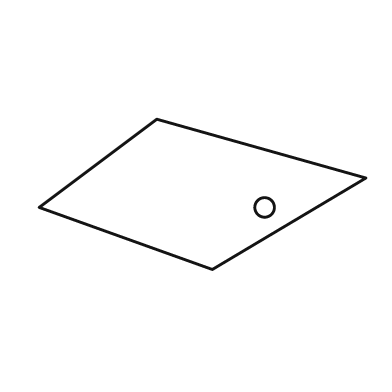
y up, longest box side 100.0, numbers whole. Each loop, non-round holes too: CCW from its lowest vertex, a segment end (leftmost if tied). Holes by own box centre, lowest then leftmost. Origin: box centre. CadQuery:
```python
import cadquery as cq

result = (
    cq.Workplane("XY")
    .moveTo(3.0, -23.0)
    .lineTo(50.0, 5.0)
    .lineTo(-14.0, 23.0)
    .lineTo(-50.0, -4.0)
    .close()
    .moveTo(19.0, -4.0)
    .circle(3.0)
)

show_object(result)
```